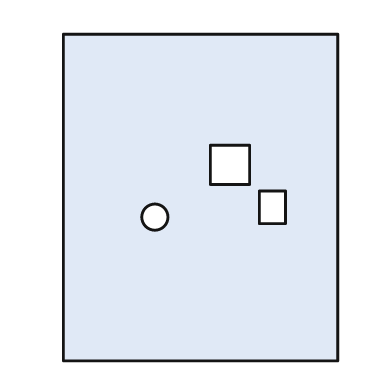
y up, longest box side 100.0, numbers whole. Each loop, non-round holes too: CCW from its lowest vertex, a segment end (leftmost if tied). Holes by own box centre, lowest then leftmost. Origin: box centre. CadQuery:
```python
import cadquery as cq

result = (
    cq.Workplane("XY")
    .moveTo(-42.0, -50.0)
    .lineTo(42.0, -50.0)
    .lineTo(42.0, 50.0)
    .lineTo(-42.0, 50.0)
    .close()
    .moveTo(-14.0, -6.0)
    .circle(4.0)
    .moveTo(18.0, -8.0)
    .lineTo(26.0, -8.0)
    .lineTo(26.0, 2.0)
    .lineTo(18.0, 2.0)
    .close()
    .moveTo(3.0, 4.0)
    .lineTo(15.0, 4.0)
    .lineTo(15.0, 16.0)
    .lineTo(3.0, 16.0)
    .close()
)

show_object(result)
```